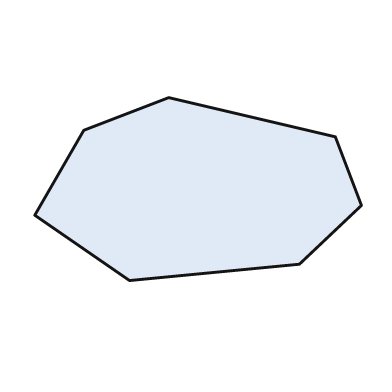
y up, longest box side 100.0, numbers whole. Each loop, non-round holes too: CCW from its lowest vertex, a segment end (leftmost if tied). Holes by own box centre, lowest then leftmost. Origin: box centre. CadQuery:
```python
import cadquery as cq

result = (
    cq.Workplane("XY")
    .moveTo(-21.0, -28.0)
    .lineTo(31.0, -23.0)
    .lineTo(50.0, -5.0)
    .lineTo(42.0, 16.0)
    .lineTo(-9.0, 28.0)
    .lineTo(-35.0, 18.0)
    .lineTo(-50.0, -8.0)
    .close()
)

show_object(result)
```